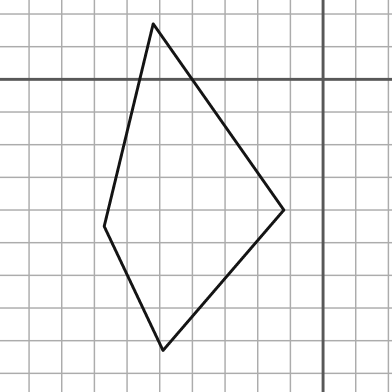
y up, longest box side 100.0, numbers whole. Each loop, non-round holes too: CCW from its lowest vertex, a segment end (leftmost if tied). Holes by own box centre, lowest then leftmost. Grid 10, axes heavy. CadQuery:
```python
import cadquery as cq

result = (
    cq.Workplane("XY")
    .moveTo(-49.0, -83.0)
    .lineTo(-12.0, -40.0)
    .lineTo(-52.0, 17.0)
    .lineTo(-67.0, -45.0)
    .close()
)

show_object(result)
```